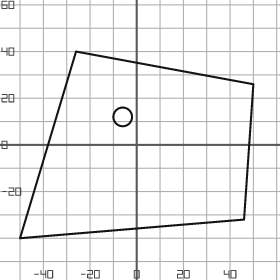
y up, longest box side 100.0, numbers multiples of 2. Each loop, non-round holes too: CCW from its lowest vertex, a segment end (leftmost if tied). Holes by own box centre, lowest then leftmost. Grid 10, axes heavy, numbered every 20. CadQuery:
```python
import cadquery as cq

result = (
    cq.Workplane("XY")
    .moveTo(-50.0, -40.0)
    .lineTo(46.0, -32.0)
    .lineTo(50.0, 26.0)
    .lineTo(-26.0, 40.0)
    .close()
    .moveTo(-6.0, 12.0)
    .circle(4.0)
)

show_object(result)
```